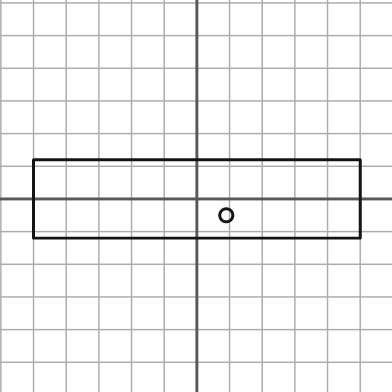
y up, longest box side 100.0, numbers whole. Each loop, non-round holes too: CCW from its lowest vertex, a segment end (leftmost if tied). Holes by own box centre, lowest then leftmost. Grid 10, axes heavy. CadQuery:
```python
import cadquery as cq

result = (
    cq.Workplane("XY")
    .moveTo(-50.0, -12.0)
    .lineTo(50.0, -12.0)
    .lineTo(50.0, 12.0)
    .lineTo(-50.0, 12.0)
    .close()
    .moveTo(9.0, -5.0)
    .circle(2.0)
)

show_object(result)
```